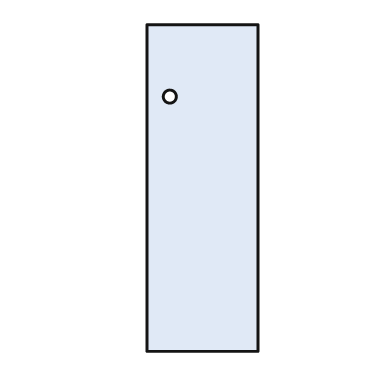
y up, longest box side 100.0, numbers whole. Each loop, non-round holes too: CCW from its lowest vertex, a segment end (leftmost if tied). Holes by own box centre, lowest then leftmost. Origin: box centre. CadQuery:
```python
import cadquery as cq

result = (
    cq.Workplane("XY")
    .moveTo(-17.0, -50.0)
    .lineTo(17.0, -50.0)
    .lineTo(17.0, 50.0)
    .lineTo(-17.0, 50.0)
    .close()
    .moveTo(-10.0, 28.0)
    .circle(2.0)
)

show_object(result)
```